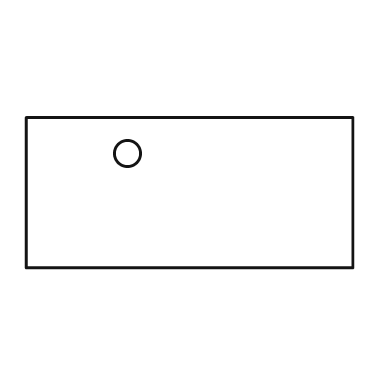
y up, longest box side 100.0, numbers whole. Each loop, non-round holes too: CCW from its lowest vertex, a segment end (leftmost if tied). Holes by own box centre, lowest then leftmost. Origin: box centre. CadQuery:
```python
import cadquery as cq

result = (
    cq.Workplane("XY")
    .moveTo(-50.0, -23.0)
    .lineTo(50.0, -23.0)
    .lineTo(50.0, 23.0)
    .lineTo(-50.0, 23.0)
    .close()
    .moveTo(-19.0, 12.0)
    .circle(4.0)
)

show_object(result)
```